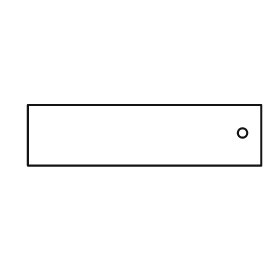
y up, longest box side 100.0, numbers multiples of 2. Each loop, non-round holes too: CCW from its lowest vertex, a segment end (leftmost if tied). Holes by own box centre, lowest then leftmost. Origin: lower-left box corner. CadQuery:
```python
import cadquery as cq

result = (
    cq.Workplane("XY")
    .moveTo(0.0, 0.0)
    .lineTo(100.0, 0.0)
    .lineTo(100.0, 26.0)
    .lineTo(0.0, 26.0)
    .close()
    .moveTo(92.0, 14.0)
    .circle(2.0)
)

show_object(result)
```